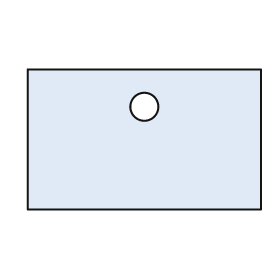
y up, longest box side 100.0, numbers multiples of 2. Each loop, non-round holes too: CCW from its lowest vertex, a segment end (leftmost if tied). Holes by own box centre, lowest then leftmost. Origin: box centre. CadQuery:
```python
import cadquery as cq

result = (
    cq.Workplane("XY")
    .moveTo(-50.0, -30.0)
    .lineTo(50.0, -30.0)
    .lineTo(50.0, 30.0)
    .lineTo(-50.0, 30.0)
    .close()
    .moveTo(0.0, 14.0)
    .circle(6.0)
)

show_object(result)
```